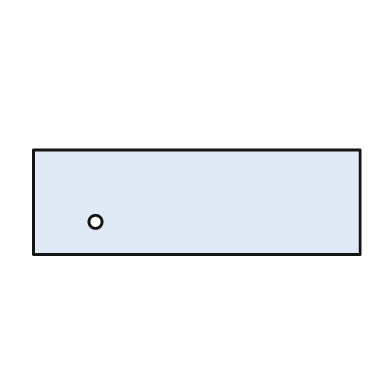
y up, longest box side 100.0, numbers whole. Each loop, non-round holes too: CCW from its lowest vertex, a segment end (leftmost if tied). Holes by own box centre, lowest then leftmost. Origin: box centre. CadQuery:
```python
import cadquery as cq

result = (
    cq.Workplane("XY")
    .moveTo(-50.0, -16.0)
    .lineTo(50.0, -16.0)
    .lineTo(50.0, 16.0)
    .lineTo(-50.0, 16.0)
    .close()
    .moveTo(-31.0, -6.0)
    .circle(2.0)
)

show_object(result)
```